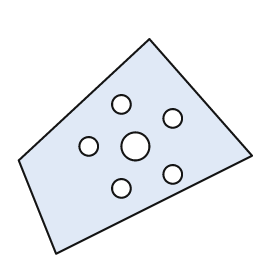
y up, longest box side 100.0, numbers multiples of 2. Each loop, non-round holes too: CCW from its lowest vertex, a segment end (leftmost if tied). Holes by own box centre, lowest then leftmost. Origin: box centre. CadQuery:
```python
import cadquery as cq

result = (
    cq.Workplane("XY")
    .moveTo(-34.0, -46.0)
    .lineTo(50.0, -4.0)
    .lineTo(6.0, 46.0)
    .lineTo(-50.0, -6.0)
    .close()
    .moveTo(-6.0, -18.0)
    .circle(4.0)
    .moveTo(16.0, -12.0)
    .circle(4.0)
    .moveTo(-20.0, 0.0)
    .circle(4.0)
    .moveTo(0.0, 0.0)
    .circle(6.0)
    .moveTo(16.0, 12.0)
    .circle(4.0)
    .moveTo(-6.0, 18.0)
    .circle(4.0)
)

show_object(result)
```